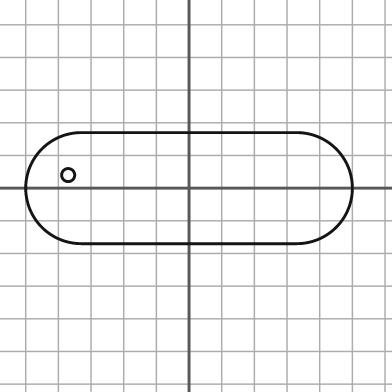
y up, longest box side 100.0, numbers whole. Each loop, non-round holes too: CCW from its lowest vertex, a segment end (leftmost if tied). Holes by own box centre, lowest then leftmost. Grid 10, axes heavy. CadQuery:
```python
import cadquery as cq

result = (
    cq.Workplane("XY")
    .moveTo(-33.0, -17.0)
    .lineTo(33.0, -17.0)
    .threePointArc((50.0, 0.0), (33.0, 17.0))
    .lineTo(-33.0, 17.0)
    .threePointArc((-50.0, 0.0), (-33.0, -17.0))
    .close()
    .moveTo(-37.0, 4.0)
    .circle(2.0)
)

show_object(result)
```